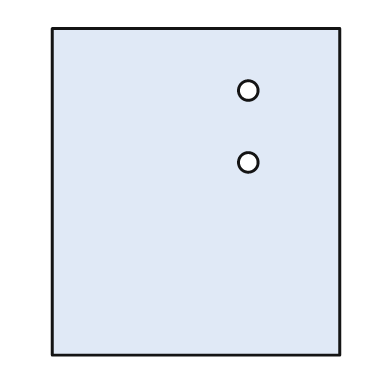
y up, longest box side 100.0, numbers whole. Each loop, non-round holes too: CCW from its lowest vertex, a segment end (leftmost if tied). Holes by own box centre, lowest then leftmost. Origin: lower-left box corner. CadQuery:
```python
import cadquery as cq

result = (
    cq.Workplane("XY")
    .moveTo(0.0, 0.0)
    .lineTo(88.0, 0.0)
    .lineTo(88.0, 100.0)
    .lineTo(0.0, 100.0)
    .close()
    .moveTo(60.0, 59.0)
    .circle(3.0)
    .moveTo(60.0, 81.0)
    .circle(3.0)
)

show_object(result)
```